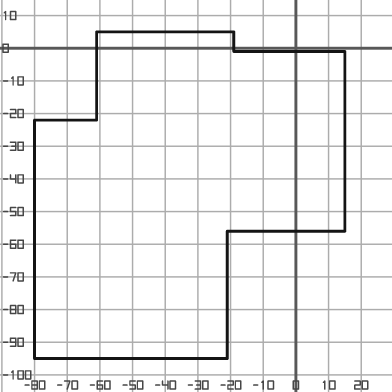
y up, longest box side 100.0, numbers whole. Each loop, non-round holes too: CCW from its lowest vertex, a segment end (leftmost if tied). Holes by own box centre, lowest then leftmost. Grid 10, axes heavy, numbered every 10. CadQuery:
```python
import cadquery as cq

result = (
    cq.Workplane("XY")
    .moveTo(-80.0, -95.0)
    .lineTo(-21.0, -95.0)
    .lineTo(-21.0, -56.0)
    .lineTo(15.0, -56.0)
    .lineTo(15.0, -1.0)
    .lineTo(-19.0, -1.0)
    .lineTo(-19.0, 5.0)
    .lineTo(-61.0, 5.0)
    .lineTo(-61.0, -22.0)
    .lineTo(-80.0, -22.0)
    .close()
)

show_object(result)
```